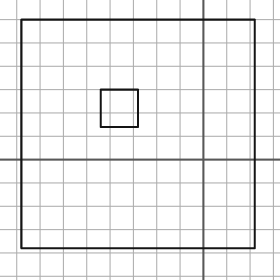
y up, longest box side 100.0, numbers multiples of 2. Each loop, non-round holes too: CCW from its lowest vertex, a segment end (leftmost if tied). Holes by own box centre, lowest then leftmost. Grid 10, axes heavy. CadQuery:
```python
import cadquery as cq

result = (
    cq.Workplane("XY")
    .moveTo(-78.0, -38.0)
    .lineTo(22.0, -38.0)
    .lineTo(22.0, 60.0)
    .lineTo(-78.0, 60.0)
    .close()
    .moveTo(-44.0, 14.0)
    .lineTo(-28.0, 14.0)
    .lineTo(-28.0, 30.0)
    .lineTo(-44.0, 30.0)
    .close()
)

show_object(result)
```